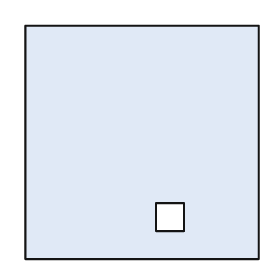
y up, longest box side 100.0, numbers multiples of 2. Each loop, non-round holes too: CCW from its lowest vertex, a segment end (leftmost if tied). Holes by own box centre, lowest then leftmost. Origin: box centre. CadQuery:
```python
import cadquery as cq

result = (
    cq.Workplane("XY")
    .moveTo(-50.0, -50.0)
    .lineTo(50.0, -50.0)
    .lineTo(50.0, 50.0)
    .lineTo(-50.0, 50.0)
    .close()
    .moveTo(6.0, -38.0)
    .lineTo(18.0, -38.0)
    .lineTo(18.0, -26.0)
    .lineTo(6.0, -26.0)
    .close()
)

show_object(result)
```